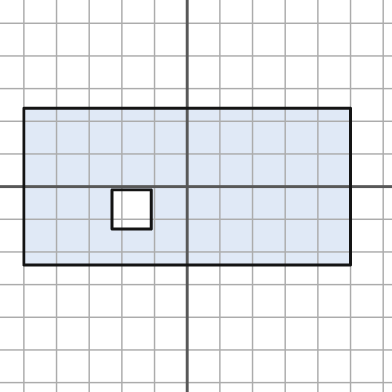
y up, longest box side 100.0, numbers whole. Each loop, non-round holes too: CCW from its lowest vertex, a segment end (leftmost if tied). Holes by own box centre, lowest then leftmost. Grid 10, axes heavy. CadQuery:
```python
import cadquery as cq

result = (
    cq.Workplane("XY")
    .moveTo(-50.0, -24.0)
    .lineTo(50.0, -24.0)
    .lineTo(50.0, 24.0)
    .lineTo(-50.0, 24.0)
    .close()
    .moveTo(-23.0, -13.0)
    .lineTo(-11.0, -13.0)
    .lineTo(-11.0, -1.0)
    .lineTo(-23.0, -1.0)
    .close()
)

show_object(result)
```